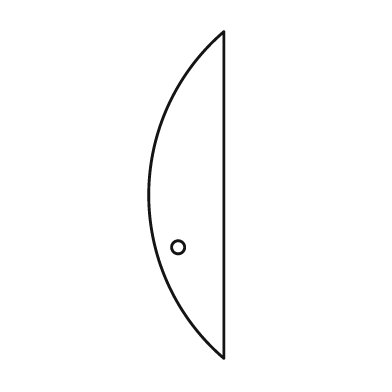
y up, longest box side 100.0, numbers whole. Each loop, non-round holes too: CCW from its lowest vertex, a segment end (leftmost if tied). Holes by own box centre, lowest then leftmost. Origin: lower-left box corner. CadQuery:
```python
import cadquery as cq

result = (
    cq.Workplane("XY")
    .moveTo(23.0, 0.0)
    .lineTo(23.0, 100.0)
    .threePointArc((0.0, 50.0), (23.0, 0.0))
    .close()
    .moveTo(9.0, 34.0)
    .circle(2.0)
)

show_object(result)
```